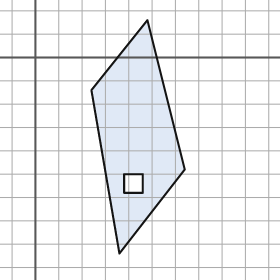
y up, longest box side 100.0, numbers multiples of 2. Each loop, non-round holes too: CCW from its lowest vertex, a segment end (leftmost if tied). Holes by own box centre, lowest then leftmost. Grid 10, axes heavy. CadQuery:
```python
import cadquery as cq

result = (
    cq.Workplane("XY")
    .moveTo(36.0, -84.0)
    .lineTo(64.0, -48.0)
    .lineTo(48.0, 16.0)
    .lineTo(24.0, -14.0)
    .close()
    .moveTo(38.0, -58.0)
    .lineTo(46.0, -58.0)
    .lineTo(46.0, -50.0)
    .lineTo(38.0, -50.0)
    .close()
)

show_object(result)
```